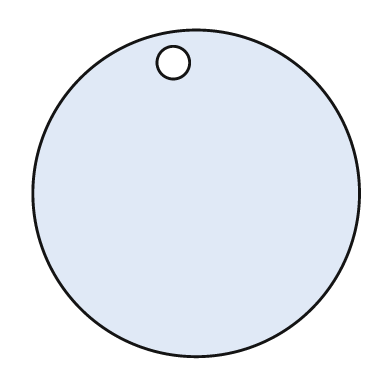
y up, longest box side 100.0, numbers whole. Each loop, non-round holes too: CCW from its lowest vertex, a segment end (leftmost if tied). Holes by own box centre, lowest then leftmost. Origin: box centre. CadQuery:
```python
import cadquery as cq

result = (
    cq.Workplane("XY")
    .moveTo(0.0, 0.0)
    .circle(50.0)
    .moveTo(-7.0, 40.0)
    .circle(5.0)
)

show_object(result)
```